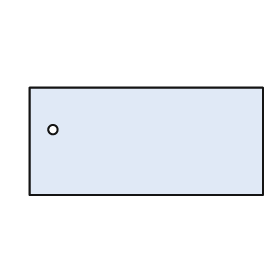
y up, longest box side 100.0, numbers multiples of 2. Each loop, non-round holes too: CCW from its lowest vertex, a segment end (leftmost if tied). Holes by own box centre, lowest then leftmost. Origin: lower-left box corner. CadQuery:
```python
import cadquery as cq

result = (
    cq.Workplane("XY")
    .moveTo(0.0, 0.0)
    .lineTo(100.0, 0.0)
    .lineTo(100.0, 46.0)
    .lineTo(0.0, 46.0)
    .close()
    .moveTo(10.0, 28.0)
    .circle(2.0)
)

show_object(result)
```